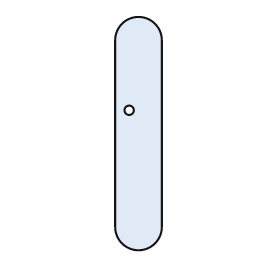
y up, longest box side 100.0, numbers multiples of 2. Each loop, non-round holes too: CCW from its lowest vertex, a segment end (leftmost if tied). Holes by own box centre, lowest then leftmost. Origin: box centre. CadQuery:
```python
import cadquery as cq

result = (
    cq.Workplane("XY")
    .moveTo(-10.0, -40.0)
    .threePointArc((0.0, -50.0), (10.0, -40.0))
    .lineTo(10.0, 40.0)
    .threePointArc((0.0, 50.0), (-10.0, 40.0))
    .close()
    .moveTo(-4.0, 10.0)
    .circle(2.0)
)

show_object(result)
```